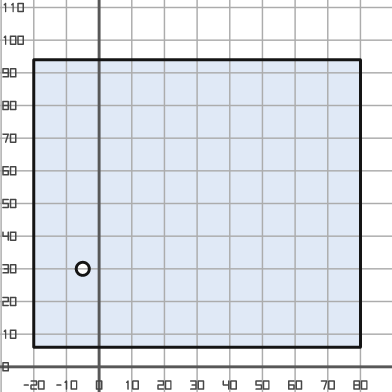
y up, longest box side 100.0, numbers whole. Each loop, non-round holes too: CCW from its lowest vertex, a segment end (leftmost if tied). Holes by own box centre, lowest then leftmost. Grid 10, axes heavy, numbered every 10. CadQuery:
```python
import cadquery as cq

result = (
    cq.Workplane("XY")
    .moveTo(-20.0, 6.0)
    .lineTo(80.0, 6.0)
    .lineTo(80.0, 94.0)
    .lineTo(-20.0, 94.0)
    .close()
    .moveTo(-5.0, 30.0)
    .circle(2.0)
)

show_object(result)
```